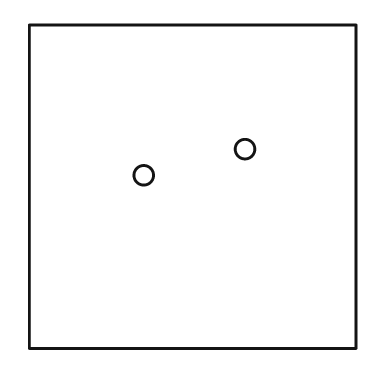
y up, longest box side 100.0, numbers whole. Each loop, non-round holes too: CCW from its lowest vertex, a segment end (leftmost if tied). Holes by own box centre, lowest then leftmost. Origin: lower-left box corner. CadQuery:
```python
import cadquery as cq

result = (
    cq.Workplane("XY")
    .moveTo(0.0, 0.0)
    .lineTo(100.0, 0.0)
    .lineTo(100.0, 99.0)
    .lineTo(0.0, 99.0)
    .close()
    .moveTo(35.0, 53.0)
    .circle(3.0)
    .moveTo(66.0, 61.0)
    .circle(3.0)
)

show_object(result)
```